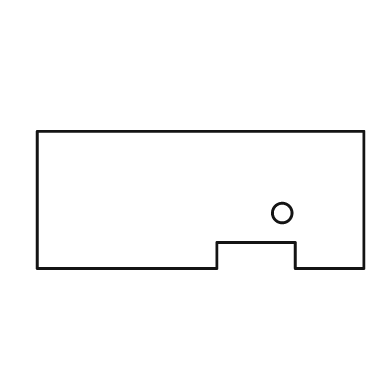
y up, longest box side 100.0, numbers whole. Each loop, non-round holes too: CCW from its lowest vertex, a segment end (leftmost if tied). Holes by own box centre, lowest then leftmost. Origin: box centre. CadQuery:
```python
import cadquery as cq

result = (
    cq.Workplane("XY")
    .moveTo(-50.0, -21.0)
    .lineTo(5.0, -21.0)
    .lineTo(5.0, -13.0)
    .lineTo(29.0, -13.0)
    .lineTo(29.0, -21.0)
    .lineTo(50.0, -21.0)
    .lineTo(50.0, 21.0)
    .lineTo(-50.0, 21.0)
    .close()
    .moveTo(25.0, -4.0)
    .circle(3.0)
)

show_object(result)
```